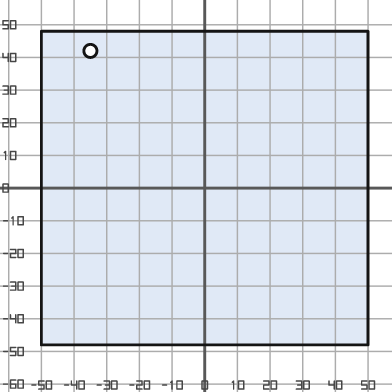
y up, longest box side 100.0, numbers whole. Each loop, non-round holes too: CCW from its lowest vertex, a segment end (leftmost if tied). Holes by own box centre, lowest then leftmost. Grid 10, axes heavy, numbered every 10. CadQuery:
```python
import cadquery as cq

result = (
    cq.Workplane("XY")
    .moveTo(-50.0, -48.0)
    .lineTo(50.0, -48.0)
    .lineTo(50.0, 48.0)
    .lineTo(-50.0, 48.0)
    .close()
    .moveTo(-35.0, 42.0)
    .circle(2.0)
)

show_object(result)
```